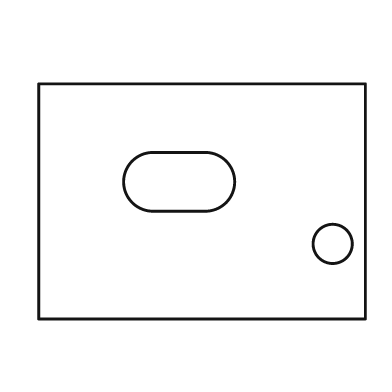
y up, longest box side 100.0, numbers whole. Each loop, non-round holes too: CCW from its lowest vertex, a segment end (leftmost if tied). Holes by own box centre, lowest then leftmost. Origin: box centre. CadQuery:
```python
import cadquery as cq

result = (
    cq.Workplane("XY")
    .moveTo(-50.0, -36.0)
    .lineTo(50.0, -36.0)
    .lineTo(50.0, 36.0)
    .lineTo(-50.0, 36.0)
    .close()
    .moveTo(40.0, -13.0)
    .circle(6.0)
    .moveTo(-15.0, -3.0)
    .lineTo(1.0, -3.0)
    .threePointArc((10.0, 6.0), (1.0, 15.0))
    .lineTo(-15.0, 15.0)
    .threePointArc((-24.0, 6.0), (-15.0, -3.0))
    .close()
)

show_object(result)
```